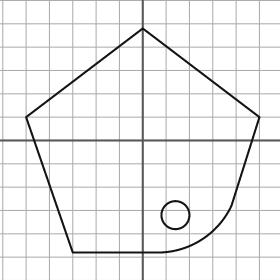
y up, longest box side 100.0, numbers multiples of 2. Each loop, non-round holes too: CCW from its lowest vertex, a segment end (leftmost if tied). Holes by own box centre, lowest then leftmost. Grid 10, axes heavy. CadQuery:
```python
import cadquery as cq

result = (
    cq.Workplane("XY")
    .moveTo(-30.0, -48.0)
    .lineTo(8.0, -48.0)
    .threePointArc((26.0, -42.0), (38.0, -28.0))
    .lineTo(50.0, 10.0)
    .lineTo(0.0, 48.0)
    .lineTo(-50.0, 10.0)
    .close()
    .moveTo(14.0, -32.0)
    .circle(6.0)
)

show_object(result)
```